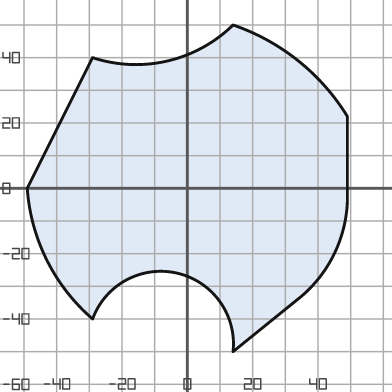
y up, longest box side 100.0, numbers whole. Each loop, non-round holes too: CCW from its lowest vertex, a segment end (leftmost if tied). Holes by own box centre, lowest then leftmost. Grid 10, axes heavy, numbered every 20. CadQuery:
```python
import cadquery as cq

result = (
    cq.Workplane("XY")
    .moveTo(14.0, -50.0)
    .lineTo(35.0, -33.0)
    .threePointArc((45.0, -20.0), (49.0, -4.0))
    .lineTo(49.0, 22.0)
    .threePointArc((34.0, 39.0), (14.0, 50.0))
    .threePointArc((-6.0, 39.0), (-29.0, 40.0))
    .lineTo(-49.0, 0.0)
    .threePointArc((-43.0, -22.0), (-29.0, -40.0))
    .threePointArc((-3.0, -26.0), (14.0, -50.0))
    .close()
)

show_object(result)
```